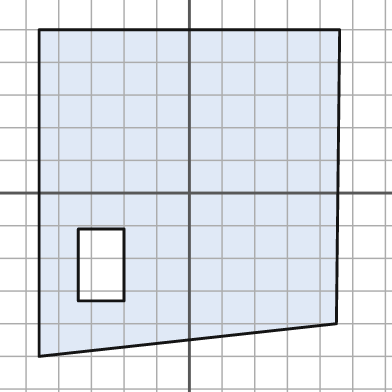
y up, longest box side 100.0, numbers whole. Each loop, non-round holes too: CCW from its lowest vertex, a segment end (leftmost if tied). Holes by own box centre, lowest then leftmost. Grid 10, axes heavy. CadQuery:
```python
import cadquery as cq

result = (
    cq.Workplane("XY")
    .moveTo(-46.0, -50.0)
    .lineTo(45.0, -40.0)
    .lineTo(46.0, 50.0)
    .lineTo(-46.0, 50.0)
    .close()
    .moveTo(-34.0, -33.0)
    .lineTo(-20.0, -33.0)
    .lineTo(-20.0, -11.0)
    .lineTo(-34.0, -11.0)
    .close()
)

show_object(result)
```